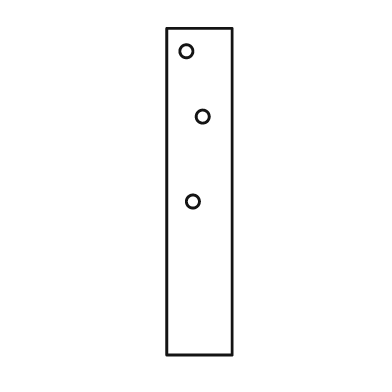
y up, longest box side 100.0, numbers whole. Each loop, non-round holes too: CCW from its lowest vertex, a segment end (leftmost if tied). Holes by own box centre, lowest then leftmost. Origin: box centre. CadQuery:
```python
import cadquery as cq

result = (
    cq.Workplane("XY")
    .moveTo(-10.0, -50.0)
    .lineTo(10.0, -50.0)
    .lineTo(10.0, 50.0)
    .lineTo(-10.0, 50.0)
    .close()
    .moveTo(-2.0, -3.0)
    .circle(2.0)
    .moveTo(1.0, 23.0)
    .circle(2.0)
    .moveTo(-4.0, 43.0)
    .circle(2.0)
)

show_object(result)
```